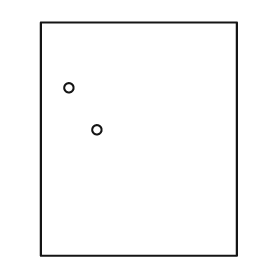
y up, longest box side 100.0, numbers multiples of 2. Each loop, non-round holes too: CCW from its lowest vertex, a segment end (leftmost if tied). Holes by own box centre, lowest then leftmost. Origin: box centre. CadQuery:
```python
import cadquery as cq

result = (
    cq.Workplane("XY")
    .moveTo(-42.0, -50.0)
    .lineTo(42.0, -50.0)
    .lineTo(42.0, 50.0)
    .lineTo(-42.0, 50.0)
    .close()
    .moveTo(-18.0, 4.0)
    .circle(2.0)
    .moveTo(-30.0, 22.0)
    .circle(2.0)
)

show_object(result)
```